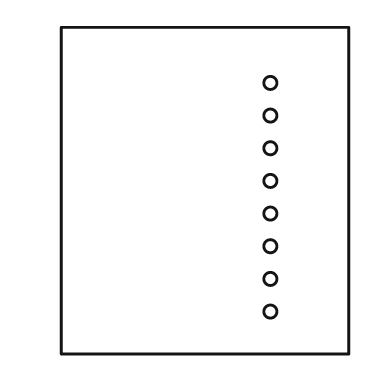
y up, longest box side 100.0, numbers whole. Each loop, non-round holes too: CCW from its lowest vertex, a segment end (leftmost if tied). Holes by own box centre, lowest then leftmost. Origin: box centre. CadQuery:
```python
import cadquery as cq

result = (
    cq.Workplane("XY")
    .moveTo(-44.0, -50.0)
    .lineTo(44.0, -50.0)
    .lineTo(44.0, 50.0)
    .lineTo(-44.0, 50.0)
    .close()
    .moveTo(20.0, -37.0)
    .circle(2.0)
    .moveTo(20.0, -27.0)
    .circle(2.0)
    .moveTo(20.0, -17.0)
    .circle(2.0)
    .moveTo(20.0, -7.0)
    .circle(2.0)
    .moveTo(20.0, 3.0)
    .circle(2.0)
    .moveTo(20.0, 13.0)
    .circle(2.0)
    .moveTo(20.0, 23.0)
    .circle(2.0)
    .moveTo(20.0, 33.0)
    .circle(2.0)
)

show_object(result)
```